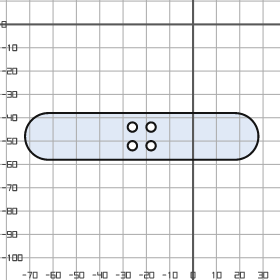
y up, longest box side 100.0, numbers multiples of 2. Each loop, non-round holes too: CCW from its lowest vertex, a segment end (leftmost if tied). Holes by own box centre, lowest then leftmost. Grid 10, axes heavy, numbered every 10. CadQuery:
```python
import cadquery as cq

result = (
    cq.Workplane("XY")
    .moveTo(-62.0, -58.0)
    .lineTo(18.0, -58.0)
    .threePointArc((28.0, -48.0), (18.0, -38.0))
    .lineTo(-62.0, -38.0)
    .threePointArc((-72.0, -48.0), (-62.0, -58.0))
    .close()
    .moveTo(-26.0, -52.0)
    .circle(2.0)
    .moveTo(-18.0, -52.0)
    .circle(2.0)
    .moveTo(-26.0, -44.0)
    .circle(2.0)
    .moveTo(-18.0, -44.0)
    .circle(2.0)
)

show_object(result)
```